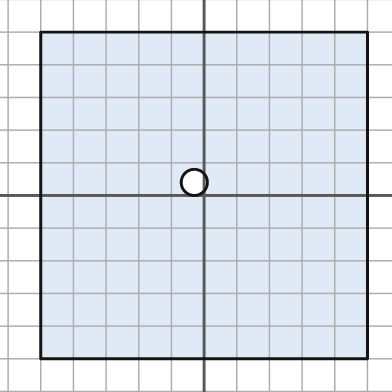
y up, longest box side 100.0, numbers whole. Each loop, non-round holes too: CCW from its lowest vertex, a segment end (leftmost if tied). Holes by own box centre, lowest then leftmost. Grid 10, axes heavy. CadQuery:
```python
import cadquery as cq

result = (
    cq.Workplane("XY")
    .moveTo(-50.0, -50.0)
    .lineTo(50.0, -50.0)
    .lineTo(50.0, 50.0)
    .lineTo(-50.0, 50.0)
    .close()
    .moveTo(-3.0, 4.0)
    .circle(4.0)
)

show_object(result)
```